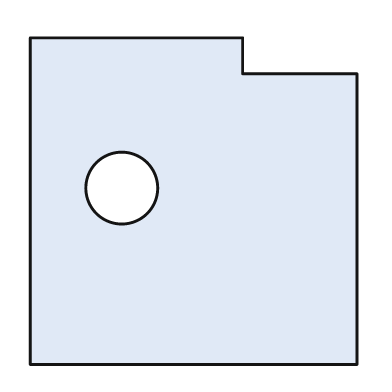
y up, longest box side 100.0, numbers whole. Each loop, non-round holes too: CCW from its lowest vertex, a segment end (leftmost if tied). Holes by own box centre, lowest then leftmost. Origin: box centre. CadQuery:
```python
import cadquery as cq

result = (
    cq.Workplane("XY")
    .moveTo(-50.0, -50.0)
    .lineTo(50.0, -50.0)
    .lineTo(50.0, 39.0)
    .lineTo(15.0, 39.0)
    .lineTo(15.0, 50.0)
    .lineTo(-50.0, 50.0)
    .close()
    .moveTo(-22.0, 4.0)
    .circle(11.0)
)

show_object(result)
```